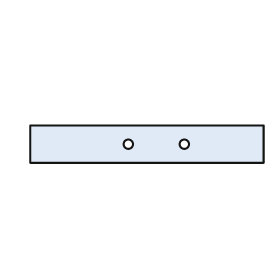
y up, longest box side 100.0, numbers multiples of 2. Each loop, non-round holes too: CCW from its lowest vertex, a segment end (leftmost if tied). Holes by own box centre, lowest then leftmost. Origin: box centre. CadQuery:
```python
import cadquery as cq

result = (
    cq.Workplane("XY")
    .moveTo(-50.0, -8.0)
    .lineTo(50.0, -8.0)
    .lineTo(50.0, 8.0)
    .lineTo(-50.0, 8.0)
    .close()
    .moveTo(-8.0, 0.0)
    .circle(2.0)
    .moveTo(16.0, 0.0)
    .circle(2.0)
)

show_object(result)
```